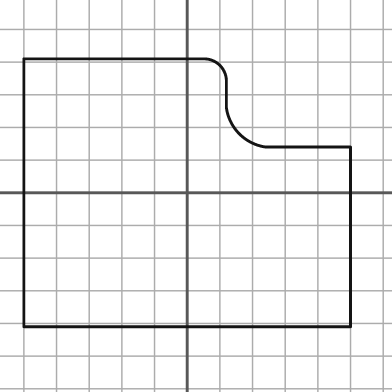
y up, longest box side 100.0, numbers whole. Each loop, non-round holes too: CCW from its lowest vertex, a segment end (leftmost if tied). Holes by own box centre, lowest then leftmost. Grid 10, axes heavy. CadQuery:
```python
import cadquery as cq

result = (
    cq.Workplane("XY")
    .moveTo(-50.0, -41.0)
    .lineTo(50.0, -41.0)
    .lineTo(50.0, 14.0)
    .lineTo(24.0, 14.0)
    .threePointArc((16.0, 18.0), (12.0, 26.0))
    .lineTo(12.0, 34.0)
    .threePointArc((10.0, 39.0), (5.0, 41.0))
    .lineTo(-50.0, 41.0)
    .close()
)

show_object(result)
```